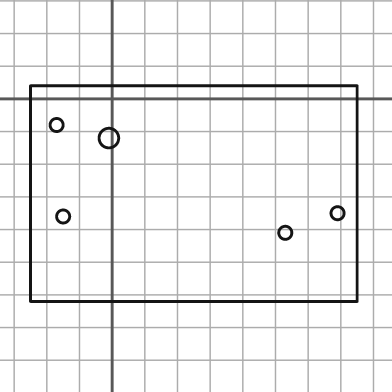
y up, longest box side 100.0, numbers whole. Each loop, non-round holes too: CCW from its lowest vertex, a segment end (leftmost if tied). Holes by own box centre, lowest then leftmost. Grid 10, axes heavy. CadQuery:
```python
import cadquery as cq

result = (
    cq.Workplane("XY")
    .moveTo(-25.0, -62.0)
    .lineTo(75.0, -62.0)
    .lineTo(75.0, 4.0)
    .lineTo(-25.0, 4.0)
    .close()
    .moveTo(53.0, -41.0)
    .circle(2.0)
    .moveTo(-15.0, -36.0)
    .circle(2.0)
    .moveTo(69.0, -35.0)
    .circle(2.0)
    .moveTo(-1.0, -12.0)
    .circle(3.0)
    .moveTo(-17.0, -8.0)
    .circle(2.0)
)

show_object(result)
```